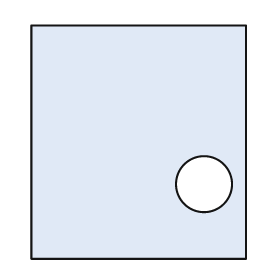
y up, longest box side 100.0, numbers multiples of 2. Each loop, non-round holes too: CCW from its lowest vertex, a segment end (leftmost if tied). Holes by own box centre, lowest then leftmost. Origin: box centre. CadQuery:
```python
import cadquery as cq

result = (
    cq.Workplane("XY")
    .moveTo(-46.0, -50.0)
    .lineTo(46.0, -50.0)
    .lineTo(46.0, 50.0)
    .lineTo(-46.0, 50.0)
    .close()
    .moveTo(28.0, -18.0)
    .circle(12.0)
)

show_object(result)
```